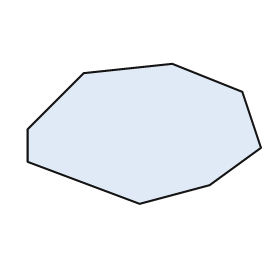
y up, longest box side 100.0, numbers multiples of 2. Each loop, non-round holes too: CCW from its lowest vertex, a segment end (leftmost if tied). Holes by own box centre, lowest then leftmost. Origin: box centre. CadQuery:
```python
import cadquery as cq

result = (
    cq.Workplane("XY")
    .moveTo(-2.0, -30.0)
    .lineTo(28.0, -22.0)
    .lineTo(50.0, -6.0)
    .lineTo(42.0, 18.0)
    .lineTo(12.0, 30.0)
    .lineTo(-26.0, 26.0)
    .lineTo(-50.0, 2.0)
    .lineTo(-50.0, -12.0)
    .close()
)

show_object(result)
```